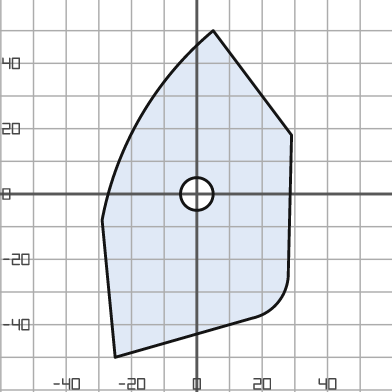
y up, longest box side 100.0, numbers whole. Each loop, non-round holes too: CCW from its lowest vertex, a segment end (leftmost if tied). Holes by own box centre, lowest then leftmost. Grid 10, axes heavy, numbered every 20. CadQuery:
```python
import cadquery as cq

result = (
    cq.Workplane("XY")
    .moveTo(-25.0, -50.0)
    .lineTo(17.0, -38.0)
    .threePointArc((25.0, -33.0), (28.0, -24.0))
    .lineTo(29.0, 18.0)
    .lineTo(5.0, 50.0)
    .threePointArc((-17.0, 24.0), (-29.0, -8.0))
    .close()
    .moveTo(0.0, 0.0)
    .circle(5.0)
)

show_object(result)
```